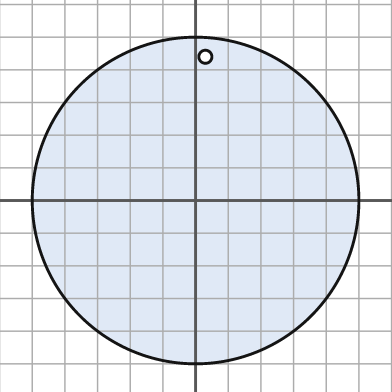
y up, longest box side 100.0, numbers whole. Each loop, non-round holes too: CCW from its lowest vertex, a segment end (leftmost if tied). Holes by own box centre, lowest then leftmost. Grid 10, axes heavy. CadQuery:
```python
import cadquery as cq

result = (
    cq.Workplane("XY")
    .moveTo(0.0, 0.0)
    .circle(50.0)
    .moveTo(3.0, 44.0)
    .circle(2.0)
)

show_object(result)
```